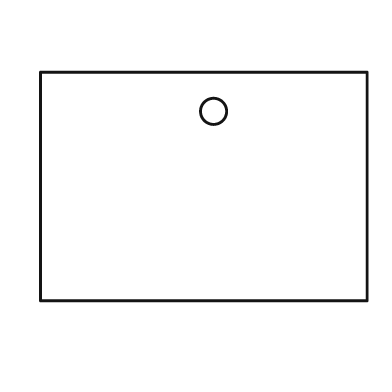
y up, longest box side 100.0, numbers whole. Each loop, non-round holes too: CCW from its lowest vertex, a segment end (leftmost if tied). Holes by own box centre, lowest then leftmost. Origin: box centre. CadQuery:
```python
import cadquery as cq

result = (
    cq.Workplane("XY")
    .moveTo(-50.0, -35.0)
    .lineTo(50.0, -35.0)
    .lineTo(50.0, 35.0)
    .lineTo(-50.0, 35.0)
    .close()
    .moveTo(3.0, 23.0)
    .circle(4.0)
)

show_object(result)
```